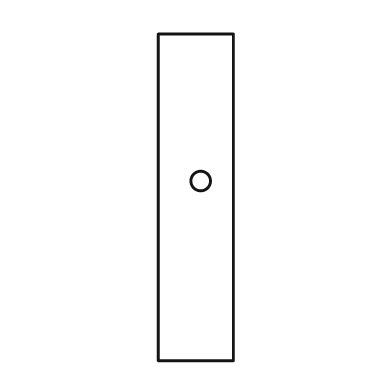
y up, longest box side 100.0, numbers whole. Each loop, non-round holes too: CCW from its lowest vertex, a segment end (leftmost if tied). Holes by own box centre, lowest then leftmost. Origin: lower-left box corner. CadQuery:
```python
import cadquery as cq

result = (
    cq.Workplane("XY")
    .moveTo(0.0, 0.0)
    .lineTo(23.0, 0.0)
    .lineTo(23.0, 100.0)
    .lineTo(0.0, 100.0)
    .close()
    .moveTo(13.0, 55.0)
    .circle(3.0)
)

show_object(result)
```